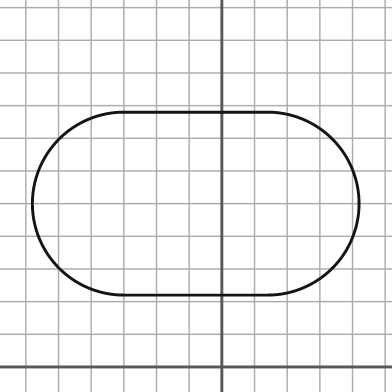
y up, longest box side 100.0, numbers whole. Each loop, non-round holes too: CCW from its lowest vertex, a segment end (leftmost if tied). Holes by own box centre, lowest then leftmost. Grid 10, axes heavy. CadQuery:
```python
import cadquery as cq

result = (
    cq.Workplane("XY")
    .moveTo(-30.0, 22.0)
    .lineTo(14.0, 22.0)
    .threePointArc((42.0, 50.0), (14.0, 78.0))
    .lineTo(-30.0, 78.0)
    .threePointArc((-58.0, 50.0), (-30.0, 22.0))
    .close()
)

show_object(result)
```